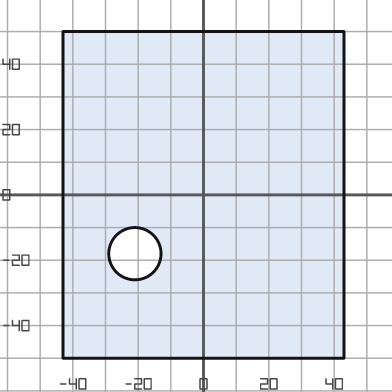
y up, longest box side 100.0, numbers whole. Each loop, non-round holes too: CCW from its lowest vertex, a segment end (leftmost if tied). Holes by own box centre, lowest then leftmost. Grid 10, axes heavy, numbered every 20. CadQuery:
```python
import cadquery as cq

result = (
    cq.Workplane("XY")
    .moveTo(-43.0, -50.0)
    .lineTo(43.0, -50.0)
    .lineTo(43.0, 50.0)
    .lineTo(-43.0, 50.0)
    .close()
    .moveTo(-21.0, -18.0)
    .circle(8.0)
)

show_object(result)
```